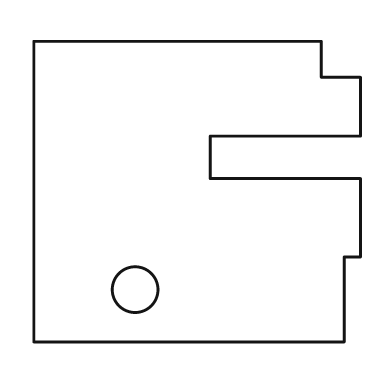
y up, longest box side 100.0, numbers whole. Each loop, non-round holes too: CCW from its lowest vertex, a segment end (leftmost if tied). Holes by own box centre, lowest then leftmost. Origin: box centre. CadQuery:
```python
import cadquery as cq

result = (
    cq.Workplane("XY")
    .moveTo(-50.0, -46.0)
    .lineTo(45.0, -46.0)
    .lineTo(45.0, -20.0)
    .lineTo(50.0, -20.0)
    .lineTo(50.0, 4.0)
    .lineTo(4.0, 4.0)
    .lineTo(4.0, 17.0)
    .lineTo(50.0, 17.0)
    .lineTo(50.0, 35.0)
    .lineTo(38.0, 35.0)
    .lineTo(38.0, 46.0)
    .lineTo(-50.0, 46.0)
    .close()
    .moveTo(-19.0, -30.0)
    .circle(7.0)
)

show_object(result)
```